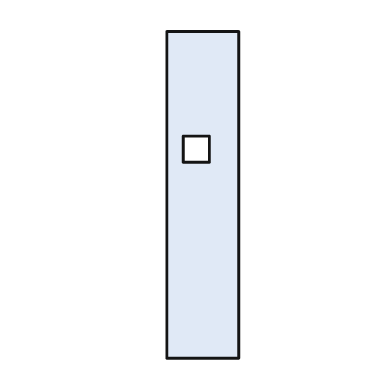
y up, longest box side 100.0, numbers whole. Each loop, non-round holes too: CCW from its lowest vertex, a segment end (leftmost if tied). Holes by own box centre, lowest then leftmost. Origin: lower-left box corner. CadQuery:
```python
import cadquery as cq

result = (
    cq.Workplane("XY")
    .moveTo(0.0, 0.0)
    .lineTo(22.0, 0.0)
    .lineTo(22.0, 100.0)
    .lineTo(0.0, 100.0)
    .close()
    .moveTo(5.0, 60.0)
    .lineTo(13.0, 60.0)
    .lineTo(13.0, 68.0)
    .lineTo(5.0, 68.0)
    .close()
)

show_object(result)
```